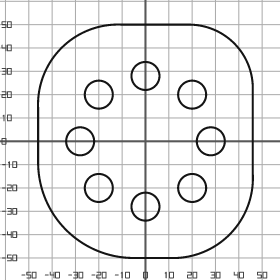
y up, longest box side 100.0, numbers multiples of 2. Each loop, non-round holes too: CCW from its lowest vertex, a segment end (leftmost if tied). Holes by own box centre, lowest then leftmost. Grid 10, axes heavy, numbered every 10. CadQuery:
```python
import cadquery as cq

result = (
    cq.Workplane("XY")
    .moveTo(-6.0, -50.0)
    .lineTo(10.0, -50.0)
    .threePointArc((36.0, -40.0), (46.0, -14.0))
    .lineTo(46.0, 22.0)
    .threePointArc((38.0, 42.0), (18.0, 50.0))
    .lineTo(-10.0, 50.0)
    .threePointArc((-36.0, 40.0), (-46.0, 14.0))
    .lineTo(-46.0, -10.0)
    .threePointArc((-34.0, -38.0), (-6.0, -50.0))
    .close()
    .moveTo(0.0, -28.0)
    .circle(6.0)
    .moveTo(-20.0, -20.0)
    .circle(6.0)
    .moveTo(20.0, -20.0)
    .circle(6.0)
    .moveTo(-28.0, 0.0)
    .circle(6.0)
    .moveTo(28.0, 0.0)
    .circle(6.0)
    .moveTo(-20.0, 20.0)
    .circle(6.0)
    .moveTo(20.0, 20.0)
    .circle(6.0)
    .moveTo(0.0, 28.0)
    .circle(6.0)
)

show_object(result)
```